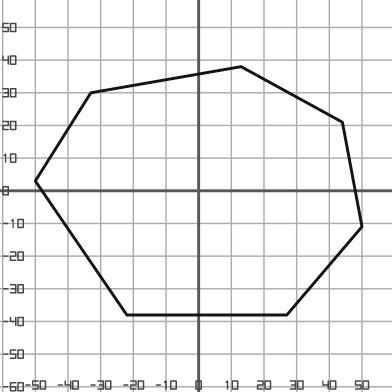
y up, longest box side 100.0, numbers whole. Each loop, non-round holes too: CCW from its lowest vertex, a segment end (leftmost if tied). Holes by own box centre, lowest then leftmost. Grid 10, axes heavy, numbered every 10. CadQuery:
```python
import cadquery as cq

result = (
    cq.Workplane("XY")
    .moveTo(-22.0, -38.0)
    .lineTo(27.0, -38.0)
    .lineTo(50.0, -11.0)
    .lineTo(44.0, 21.0)
    .lineTo(13.0, 38.0)
    .lineTo(-33.0, 30.0)
    .lineTo(-50.0, 3.0)
    .close()
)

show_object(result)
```